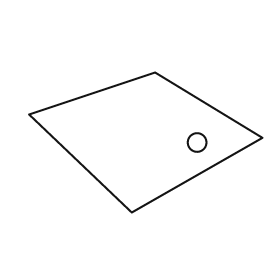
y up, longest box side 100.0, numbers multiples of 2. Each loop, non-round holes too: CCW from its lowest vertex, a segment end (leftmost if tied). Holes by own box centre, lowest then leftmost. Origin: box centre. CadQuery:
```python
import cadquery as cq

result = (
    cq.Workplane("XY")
    .moveTo(-6.0, -30.0)
    .lineTo(50.0, 2.0)
    .lineTo(4.0, 30.0)
    .lineTo(-50.0, 12.0)
    .close()
    .moveTo(22.0, 0.0)
    .circle(4.0)
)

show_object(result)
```